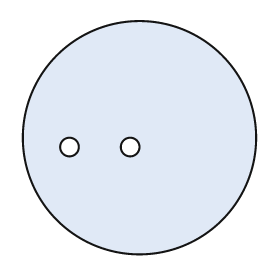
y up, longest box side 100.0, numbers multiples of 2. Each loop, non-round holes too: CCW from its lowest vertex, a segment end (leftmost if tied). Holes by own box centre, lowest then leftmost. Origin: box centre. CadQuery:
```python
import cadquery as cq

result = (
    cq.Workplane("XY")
    .moveTo(0.0, 0.0)
    .circle(50.0)
    .moveTo(-30.0, -4.0)
    .circle(4.0)
    .moveTo(-4.0, -4.0)
    .circle(4.0)
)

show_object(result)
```